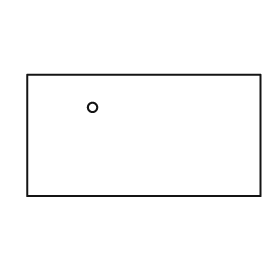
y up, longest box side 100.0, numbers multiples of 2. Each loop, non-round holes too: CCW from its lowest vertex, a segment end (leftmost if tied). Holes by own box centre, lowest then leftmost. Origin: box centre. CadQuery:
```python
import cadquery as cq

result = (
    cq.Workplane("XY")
    .moveTo(-50.0, -26.0)
    .lineTo(50.0, -26.0)
    .lineTo(50.0, 26.0)
    .lineTo(-50.0, 26.0)
    .close()
    .moveTo(-22.0, 12.0)
    .circle(2.0)
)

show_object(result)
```